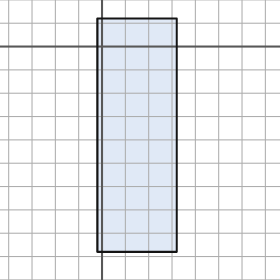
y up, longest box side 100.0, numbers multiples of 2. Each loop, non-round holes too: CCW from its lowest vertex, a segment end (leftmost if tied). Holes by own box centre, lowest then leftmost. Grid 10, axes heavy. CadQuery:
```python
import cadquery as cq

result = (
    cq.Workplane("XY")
    .moveTo(-2.0, -88.0)
    .lineTo(32.0, -88.0)
    .lineTo(32.0, 12.0)
    .lineTo(-2.0, 12.0)
    .close()
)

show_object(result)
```